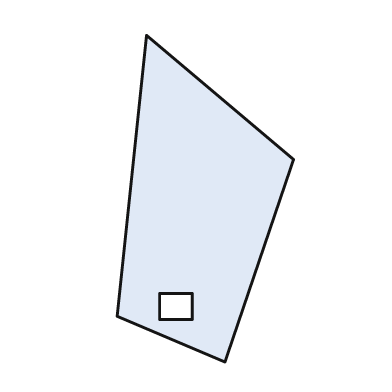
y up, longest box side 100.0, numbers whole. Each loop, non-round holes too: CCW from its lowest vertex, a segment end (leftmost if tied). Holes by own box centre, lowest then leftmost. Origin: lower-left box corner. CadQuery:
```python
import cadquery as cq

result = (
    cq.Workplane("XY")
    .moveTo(33.0, 0.0)
    .lineTo(54.0, 62.0)
    .lineTo(9.0, 100.0)
    .lineTo(0.0, 14.0)
    .close()
    .moveTo(13.0, 13.0)
    .lineTo(23.0, 13.0)
    .lineTo(23.0, 21.0)
    .lineTo(13.0, 21.0)
    .close()
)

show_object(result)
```